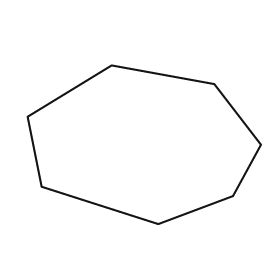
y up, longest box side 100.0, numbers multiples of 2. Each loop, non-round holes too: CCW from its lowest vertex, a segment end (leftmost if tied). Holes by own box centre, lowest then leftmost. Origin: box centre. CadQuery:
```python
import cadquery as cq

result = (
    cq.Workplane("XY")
    .moveTo(6.0, -34.0)
    .lineTo(38.0, -22.0)
    .lineTo(50.0, 0.0)
    .lineTo(30.0, 26.0)
    .lineTo(-14.0, 34.0)
    .lineTo(-50.0, 12.0)
    .lineTo(-44.0, -18.0)
    .close()
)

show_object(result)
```